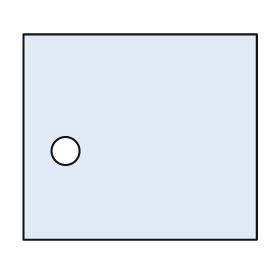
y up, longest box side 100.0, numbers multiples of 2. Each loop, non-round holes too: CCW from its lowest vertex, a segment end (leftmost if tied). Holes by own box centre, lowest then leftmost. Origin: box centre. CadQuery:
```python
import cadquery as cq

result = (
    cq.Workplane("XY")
    .moveTo(-50.0, -44.0)
    .lineTo(50.0, -44.0)
    .lineTo(50.0, 44.0)
    .lineTo(-50.0, 44.0)
    .close()
    .moveTo(-32.0, -6.0)
    .circle(6.0)
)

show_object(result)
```